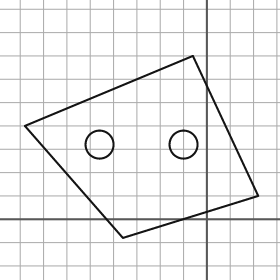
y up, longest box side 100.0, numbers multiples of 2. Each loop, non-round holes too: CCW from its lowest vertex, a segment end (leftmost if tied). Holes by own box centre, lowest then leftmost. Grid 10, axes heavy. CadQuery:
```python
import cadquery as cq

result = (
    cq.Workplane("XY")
    .moveTo(-36.0, -8.0)
    .lineTo(22.0, 10.0)
    .lineTo(-6.0, 70.0)
    .lineTo(-78.0, 40.0)
    .close()
    .moveTo(-46.0, 32.0)
    .circle(6.0)
    .moveTo(-10.0, 32.0)
    .circle(6.0)
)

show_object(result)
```